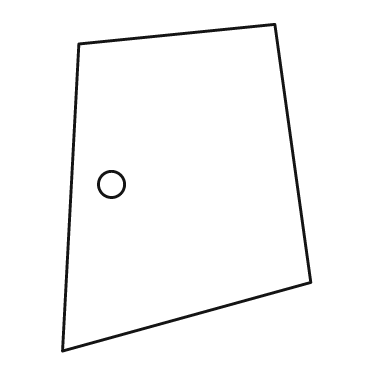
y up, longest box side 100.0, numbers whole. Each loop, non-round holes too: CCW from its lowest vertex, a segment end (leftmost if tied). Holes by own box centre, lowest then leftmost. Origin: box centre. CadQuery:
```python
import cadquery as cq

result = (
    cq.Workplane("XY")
    .moveTo(-38.0, -50.0)
    .lineTo(38.0, -29.0)
    .lineTo(27.0, 50.0)
    .lineTo(-33.0, 44.0)
    .close()
    .moveTo(-23.0, 1.0)
    .circle(4.0)
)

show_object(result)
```